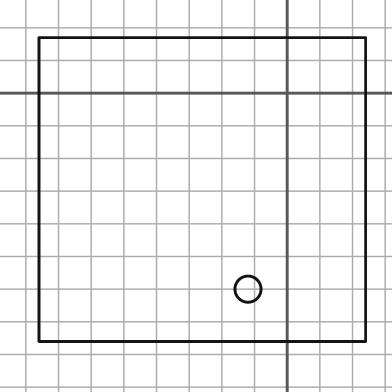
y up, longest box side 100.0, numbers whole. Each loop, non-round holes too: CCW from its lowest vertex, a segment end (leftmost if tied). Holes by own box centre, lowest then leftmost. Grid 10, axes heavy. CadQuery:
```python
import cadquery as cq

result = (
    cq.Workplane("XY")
    .moveTo(-76.0, -76.0)
    .lineTo(24.0, -76.0)
    .lineTo(24.0, 17.0)
    .lineTo(-76.0, 17.0)
    .close()
    .moveTo(-12.0, -60.0)
    .circle(4.0)
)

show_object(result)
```